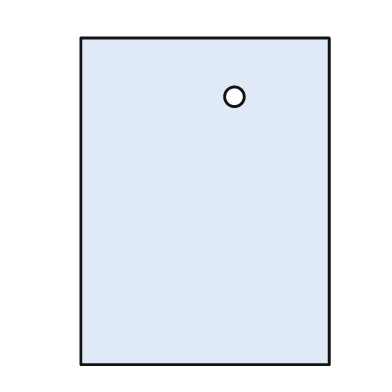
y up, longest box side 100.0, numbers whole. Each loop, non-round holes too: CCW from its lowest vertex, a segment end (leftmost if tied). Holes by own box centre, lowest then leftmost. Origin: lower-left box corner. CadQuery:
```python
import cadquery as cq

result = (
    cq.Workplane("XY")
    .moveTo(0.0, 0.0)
    .lineTo(76.0, 0.0)
    .lineTo(76.0, 100.0)
    .lineTo(0.0, 100.0)
    .close()
    .moveTo(47.0, 82.0)
    .circle(3.0)
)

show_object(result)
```